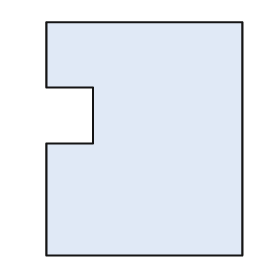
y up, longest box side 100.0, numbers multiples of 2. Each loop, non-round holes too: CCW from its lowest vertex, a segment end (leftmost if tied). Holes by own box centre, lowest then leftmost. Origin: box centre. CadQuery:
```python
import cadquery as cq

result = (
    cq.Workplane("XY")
    .moveTo(-42.0, -50.0)
    .lineTo(42.0, -50.0)
    .lineTo(42.0, 50.0)
    .lineTo(-42.0, 50.0)
    .lineTo(-42.0, 22.0)
    .lineTo(-22.0, 22.0)
    .lineTo(-22.0, -2.0)
    .lineTo(-42.0, -2.0)
    .close()
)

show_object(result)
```